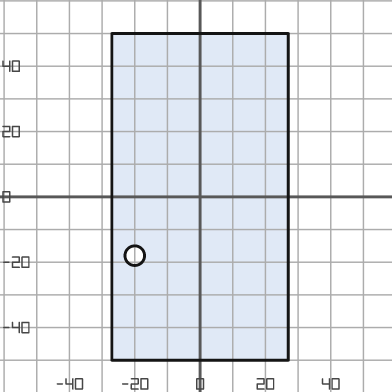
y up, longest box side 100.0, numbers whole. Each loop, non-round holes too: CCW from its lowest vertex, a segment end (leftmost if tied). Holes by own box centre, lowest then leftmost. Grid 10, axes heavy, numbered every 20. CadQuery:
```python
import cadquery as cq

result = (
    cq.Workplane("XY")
    .moveTo(-27.0, -50.0)
    .lineTo(27.0, -50.0)
    .lineTo(27.0, 50.0)
    .lineTo(-27.0, 50.0)
    .close()
    .moveTo(-20.0, -18.0)
    .circle(3.0)
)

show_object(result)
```